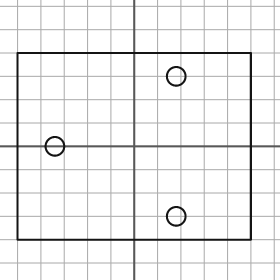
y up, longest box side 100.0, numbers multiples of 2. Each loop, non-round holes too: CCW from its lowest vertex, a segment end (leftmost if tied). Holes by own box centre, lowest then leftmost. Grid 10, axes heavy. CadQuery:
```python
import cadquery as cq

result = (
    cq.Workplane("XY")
    .moveTo(-50.0, -40.0)
    .lineTo(50.0, -40.0)
    .lineTo(50.0, 40.0)
    .lineTo(-50.0, 40.0)
    .close()
    .moveTo(18.0, -30.0)
    .circle(4.0)
    .moveTo(-34.0, 0.0)
    .circle(4.0)
    .moveTo(18.0, 30.0)
    .circle(4.0)
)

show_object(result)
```